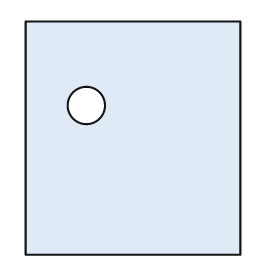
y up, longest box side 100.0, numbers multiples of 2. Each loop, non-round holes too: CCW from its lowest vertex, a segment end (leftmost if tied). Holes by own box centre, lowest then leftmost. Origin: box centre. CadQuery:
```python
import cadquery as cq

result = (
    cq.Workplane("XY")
    .moveTo(-46.0, -50.0)
    .lineTo(46.0, -50.0)
    .lineTo(46.0, 50.0)
    .lineTo(-46.0, 50.0)
    .close()
    .moveTo(-20.0, 14.0)
    .circle(8.0)
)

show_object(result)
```